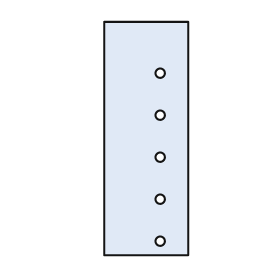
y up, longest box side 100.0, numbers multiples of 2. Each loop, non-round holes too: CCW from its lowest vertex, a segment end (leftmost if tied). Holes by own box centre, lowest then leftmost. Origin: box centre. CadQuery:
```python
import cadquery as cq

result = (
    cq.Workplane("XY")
    .moveTo(-18.0, -50.0)
    .lineTo(18.0, -50.0)
    .lineTo(18.0, 50.0)
    .lineTo(-18.0, 50.0)
    .close()
    .moveTo(6.0, -44.0)
    .circle(2.0)
    .moveTo(6.0, -26.0)
    .circle(2.0)
    .moveTo(6.0, -8.0)
    .circle(2.0)
    .moveTo(6.0, 10.0)
    .circle(2.0)
    .moveTo(6.0, 28.0)
    .circle(2.0)
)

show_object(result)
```